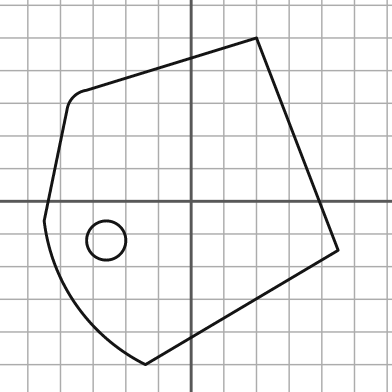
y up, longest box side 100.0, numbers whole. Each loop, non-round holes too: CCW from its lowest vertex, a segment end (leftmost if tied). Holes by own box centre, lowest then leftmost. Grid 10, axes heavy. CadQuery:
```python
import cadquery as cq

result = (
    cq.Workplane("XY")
    .moveTo(-14.0, -50.0)
    .lineTo(45.0, -15.0)
    .lineTo(20.0, 50.0)
    .lineTo(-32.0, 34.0)
    .threePointArc((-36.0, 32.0), (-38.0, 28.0))
    .lineTo(-45.0, -6.0)
    .threePointArc((-35.0, -32.0), (-14.0, -50.0))
    .close()
    .moveTo(-26.0, -12.0)
    .circle(6.0)
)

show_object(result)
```